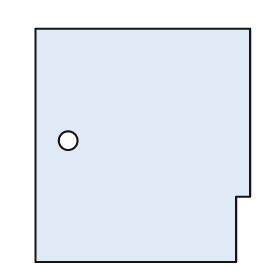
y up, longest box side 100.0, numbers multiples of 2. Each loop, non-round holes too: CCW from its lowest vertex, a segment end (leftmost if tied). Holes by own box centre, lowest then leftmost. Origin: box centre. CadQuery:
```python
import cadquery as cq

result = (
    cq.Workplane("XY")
    .moveTo(-46.0, -50.0)
    .lineTo(40.0, -50.0)
    .lineTo(40.0, -22.0)
    .lineTo(46.0, -22.0)
    .lineTo(46.0, 50.0)
    .lineTo(-46.0, 50.0)
    .close()
    .moveTo(-32.0, 2.0)
    .circle(4.0)
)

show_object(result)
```